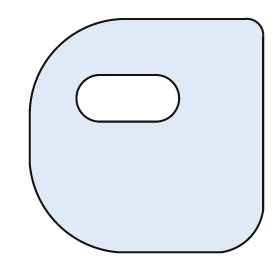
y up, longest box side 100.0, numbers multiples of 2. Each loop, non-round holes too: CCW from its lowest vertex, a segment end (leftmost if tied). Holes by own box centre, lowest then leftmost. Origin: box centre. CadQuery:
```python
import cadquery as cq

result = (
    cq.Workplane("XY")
    .moveTo(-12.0, -50.0)
    .lineTo(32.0, -50.0)
    .threePointArc((44.0, -44.0), (50.0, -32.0))
    .lineTo(50.0, 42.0)
    .threePointArc((48.0, 48.0), (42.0, 50.0))
    .lineTo(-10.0, 50.0)
    .threePointArc((-38.0, 38.0), (-50.0, 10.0))
    .lineTo(-50.0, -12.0)
    .threePointArc((-38.0, -38.0), (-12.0, -50.0))
    .close()
    .moveTo(-20.0, 6.0)
    .lineTo(4.0, 6.0)
    .threePointArc((14.0, 16.0), (4.0, 26.0))
    .lineTo(-20.0, 26.0)
    .threePointArc((-30.0, 16.0), (-20.0, 6.0))
    .close()
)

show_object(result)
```